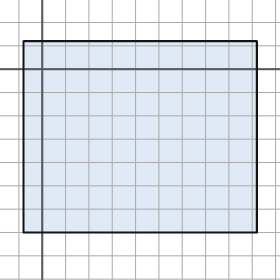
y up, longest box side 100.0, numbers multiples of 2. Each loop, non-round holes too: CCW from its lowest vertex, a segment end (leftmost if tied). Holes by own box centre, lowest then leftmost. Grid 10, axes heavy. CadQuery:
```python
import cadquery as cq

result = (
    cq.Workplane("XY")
    .moveTo(-8.0, -70.0)
    .lineTo(92.0, -70.0)
    .lineTo(92.0, 12.0)
    .lineTo(-8.0, 12.0)
    .close()
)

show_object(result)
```